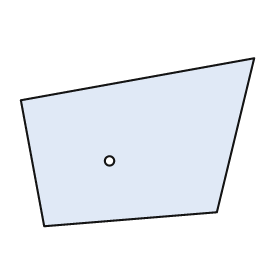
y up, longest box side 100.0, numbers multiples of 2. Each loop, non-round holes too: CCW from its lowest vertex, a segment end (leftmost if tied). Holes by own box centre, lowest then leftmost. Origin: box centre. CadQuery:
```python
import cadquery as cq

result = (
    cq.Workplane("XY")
    .moveTo(-40.0, -36.0)
    .lineTo(34.0, -30.0)
    .lineTo(50.0, 36.0)
    .lineTo(-50.0, 18.0)
    .close()
    .moveTo(-12.0, -8.0)
    .circle(2.0)
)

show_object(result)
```